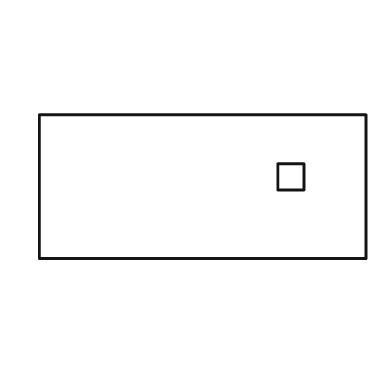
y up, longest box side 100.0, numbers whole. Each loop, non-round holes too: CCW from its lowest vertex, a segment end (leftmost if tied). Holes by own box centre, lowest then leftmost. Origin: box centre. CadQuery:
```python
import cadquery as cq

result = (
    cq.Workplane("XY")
    .moveTo(-50.0, -22.0)
    .lineTo(50.0, -22.0)
    .lineTo(50.0, 22.0)
    .lineTo(-50.0, 22.0)
    .close()
    .moveTo(23.0, -1.0)
    .lineTo(31.0, -1.0)
    .lineTo(31.0, 7.0)
    .lineTo(23.0, 7.0)
    .close()
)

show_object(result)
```